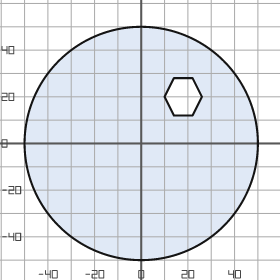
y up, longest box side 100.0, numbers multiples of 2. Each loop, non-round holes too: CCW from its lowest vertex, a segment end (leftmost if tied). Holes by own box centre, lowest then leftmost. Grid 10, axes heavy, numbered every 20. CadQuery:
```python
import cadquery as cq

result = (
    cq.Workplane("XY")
    .moveTo(0.0, 0.0)
    .circle(50.0)
    .moveTo(14.0, 12.0)
    .lineTo(22.0, 12.0)
    .lineTo(26.0, 20.0)
    .lineTo(22.0, 28.0)
    .lineTo(14.0, 28.0)
    .lineTo(10.0, 20.0)
    .close()
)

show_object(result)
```